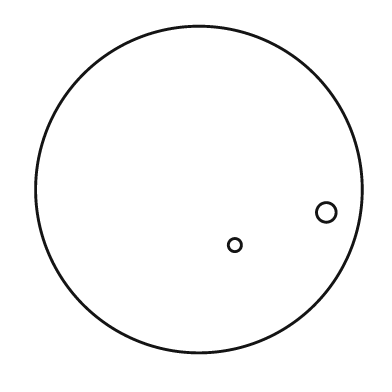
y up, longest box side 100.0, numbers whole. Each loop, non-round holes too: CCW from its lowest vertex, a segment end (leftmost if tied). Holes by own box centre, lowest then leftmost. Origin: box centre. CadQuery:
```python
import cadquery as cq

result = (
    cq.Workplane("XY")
    .moveTo(0.0, 0.0)
    .circle(50.0)
    .moveTo(11.0, -17.0)
    .circle(2.0)
    .moveTo(39.0, -7.0)
    .circle(3.0)
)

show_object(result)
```